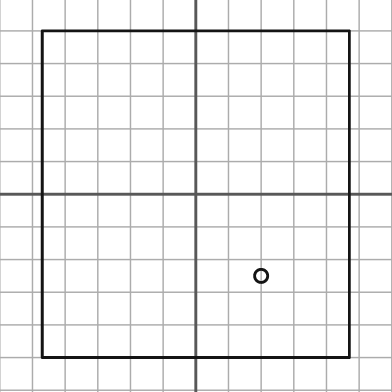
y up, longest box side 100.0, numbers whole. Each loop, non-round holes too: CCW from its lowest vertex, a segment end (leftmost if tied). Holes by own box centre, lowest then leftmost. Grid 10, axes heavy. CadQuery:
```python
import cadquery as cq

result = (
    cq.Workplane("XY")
    .moveTo(-47.0, -50.0)
    .lineTo(47.0, -50.0)
    .lineTo(47.0, 50.0)
    .lineTo(-47.0, 50.0)
    .close()
    .moveTo(20.0, -25.0)
    .circle(2.0)
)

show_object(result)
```